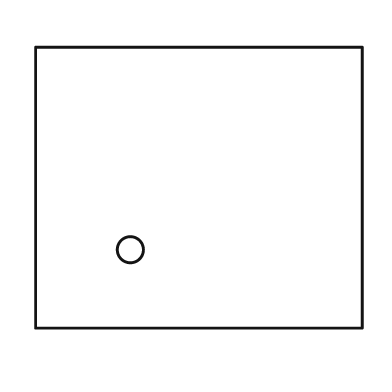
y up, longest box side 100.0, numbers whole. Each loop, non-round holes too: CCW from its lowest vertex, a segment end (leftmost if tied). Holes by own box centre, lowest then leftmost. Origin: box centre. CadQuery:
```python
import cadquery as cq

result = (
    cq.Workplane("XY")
    .moveTo(-50.0, -43.0)
    .lineTo(50.0, -43.0)
    .lineTo(50.0, 43.0)
    .lineTo(-50.0, 43.0)
    .close()
    .moveTo(-21.0, -19.0)
    .circle(4.0)
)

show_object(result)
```